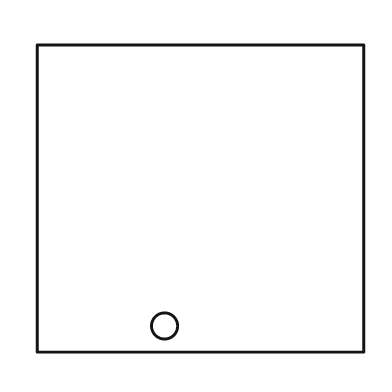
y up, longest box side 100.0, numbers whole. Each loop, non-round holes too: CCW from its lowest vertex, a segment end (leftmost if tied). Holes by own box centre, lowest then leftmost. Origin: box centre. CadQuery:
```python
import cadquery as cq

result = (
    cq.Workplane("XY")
    .moveTo(-50.0, -47.0)
    .lineTo(50.0, -47.0)
    .lineTo(50.0, 47.0)
    .lineTo(-50.0, 47.0)
    .close()
    .moveTo(-11.0, -39.0)
    .circle(4.0)
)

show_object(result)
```